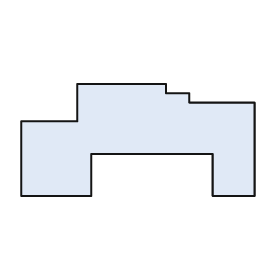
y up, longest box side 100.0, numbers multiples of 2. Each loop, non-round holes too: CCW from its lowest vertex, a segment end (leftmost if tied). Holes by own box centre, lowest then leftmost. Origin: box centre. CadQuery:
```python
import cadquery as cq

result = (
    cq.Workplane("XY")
    .moveTo(-50.0, -24.0)
    .lineTo(-20.0, -24.0)
    .lineTo(-20.0, -6.0)
    .lineTo(32.0, -6.0)
    .lineTo(32.0, -24.0)
    .lineTo(50.0, -24.0)
    .lineTo(50.0, 16.0)
    .lineTo(22.0, 16.0)
    .lineTo(22.0, 20.0)
    .lineTo(12.0, 20.0)
    .lineTo(12.0, 24.0)
    .lineTo(-26.0, 24.0)
    .lineTo(-26.0, 8.0)
    .lineTo(-50.0, 8.0)
    .close()
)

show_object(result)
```